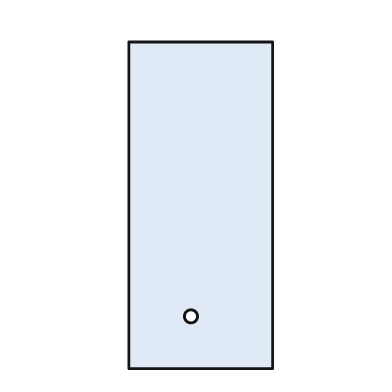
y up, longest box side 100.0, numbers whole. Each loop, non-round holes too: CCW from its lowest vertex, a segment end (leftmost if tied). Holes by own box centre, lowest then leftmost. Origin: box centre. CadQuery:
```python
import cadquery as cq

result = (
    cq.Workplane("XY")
    .moveTo(-22.0, -50.0)
    .lineTo(22.0, -50.0)
    .lineTo(22.0, 50.0)
    .lineTo(-22.0, 50.0)
    .close()
    .moveTo(-3.0, -34.0)
    .circle(2.0)
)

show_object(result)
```